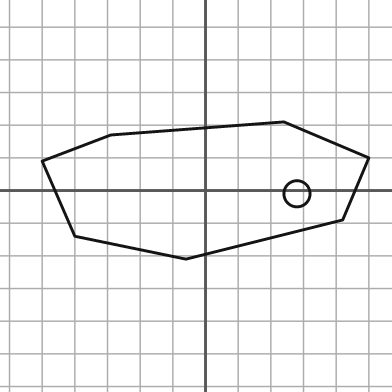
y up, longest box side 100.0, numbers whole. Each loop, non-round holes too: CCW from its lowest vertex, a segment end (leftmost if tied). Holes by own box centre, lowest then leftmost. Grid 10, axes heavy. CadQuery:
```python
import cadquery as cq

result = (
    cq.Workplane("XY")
    .moveTo(-6.0, -21.0)
    .lineTo(42.0, -9.0)
    .lineTo(50.0, 10.0)
    .lineTo(24.0, 21.0)
    .lineTo(-29.0, 17.0)
    .lineTo(-50.0, 9.0)
    .lineTo(-40.0, -14.0)
    .close()
    .moveTo(28.0, -1.0)
    .circle(4.0)
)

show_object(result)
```